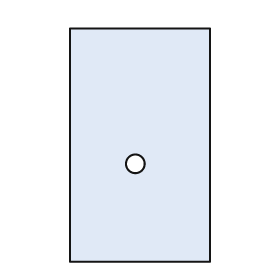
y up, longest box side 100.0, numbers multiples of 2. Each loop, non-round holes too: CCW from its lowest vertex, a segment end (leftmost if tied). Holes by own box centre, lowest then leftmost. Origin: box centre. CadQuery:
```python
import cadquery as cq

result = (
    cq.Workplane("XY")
    .moveTo(-30.0, -50.0)
    .lineTo(30.0, -50.0)
    .lineTo(30.0, 50.0)
    .lineTo(-30.0, 50.0)
    .close()
    .moveTo(-2.0, -8.0)
    .circle(4.0)
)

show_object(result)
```